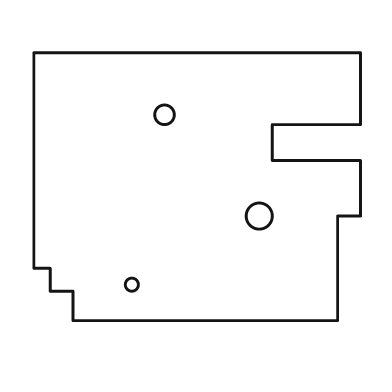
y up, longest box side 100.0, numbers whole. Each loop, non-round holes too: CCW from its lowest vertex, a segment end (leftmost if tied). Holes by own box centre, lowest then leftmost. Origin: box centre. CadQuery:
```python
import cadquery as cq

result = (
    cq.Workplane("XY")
    .moveTo(-38.0, -41.0)
    .lineTo(43.0, -41.0)
    .lineTo(43.0, -9.0)
    .lineTo(50.0, -9.0)
    .lineTo(50.0, 8.0)
    .lineTo(23.0, 8.0)
    .lineTo(23.0, 19.0)
    .lineTo(50.0, 19.0)
    .lineTo(50.0, 41.0)
    .lineTo(-50.0, 41.0)
    .lineTo(-50.0, -25.0)
    .lineTo(-45.0, -25.0)
    .lineTo(-45.0, -32.0)
    .lineTo(-38.0, -32.0)
    .close()
    .moveTo(-20.0, -30.0)
    .circle(2.0)
    .moveTo(19.0, -9.0)
    .circle(4.0)
    .moveTo(-10.0, 22.0)
    .circle(3.0)
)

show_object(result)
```